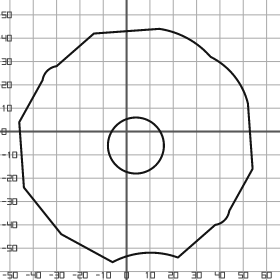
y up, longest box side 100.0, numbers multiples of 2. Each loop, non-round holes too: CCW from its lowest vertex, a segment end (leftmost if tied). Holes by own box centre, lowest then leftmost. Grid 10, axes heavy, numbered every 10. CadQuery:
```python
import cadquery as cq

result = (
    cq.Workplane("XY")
    .moveTo(-6.0, -56.0)
    .threePointArc((8.0, -52.0), (22.0, -54.0))
    .lineTo(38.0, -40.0)
    .threePointArc((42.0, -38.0), (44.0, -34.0))
    .lineTo(54.0, -16.0)
    .lineTo(52.0, 12.0)
    .threePointArc((46.0, 24.0), (36.0, 32.0))
    .threePointArc((26.0, 40.0), (14.0, 44.0))
    .lineTo(-14.0, 42.0)
    .lineTo(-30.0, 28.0)
    .threePointArc((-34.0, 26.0), (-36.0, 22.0))
    .lineTo(-46.0, 4.0)
    .lineTo(-44.0, -24.0)
    .lineTo(-28.0, -44.0)
    .close()
    .moveTo(4.0, -6.0)
    .circle(12.0)
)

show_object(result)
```